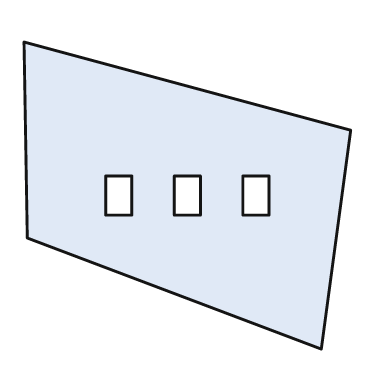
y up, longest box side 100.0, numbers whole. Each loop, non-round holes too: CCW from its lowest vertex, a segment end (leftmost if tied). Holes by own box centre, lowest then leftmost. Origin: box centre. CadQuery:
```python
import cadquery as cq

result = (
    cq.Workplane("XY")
    .moveTo(41.0, -47.0)
    .lineTo(50.0, 20.0)
    .lineTo(-50.0, 47.0)
    .lineTo(-49.0, -13.0)
    .close()
    .moveTo(-25.0, -6.0)
    .lineTo(-17.0, -6.0)
    .lineTo(-17.0, 6.0)
    .lineTo(-25.0, 6.0)
    .close()
    .moveTo(-4.0, -6.0)
    .lineTo(4.0, -6.0)
    .lineTo(4.0, 6.0)
    .lineTo(-4.0, 6.0)
    .close()
    .moveTo(17.0, -6.0)
    .lineTo(25.0, -6.0)
    .lineTo(25.0, 6.0)
    .lineTo(17.0, 6.0)
    .close()
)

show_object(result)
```